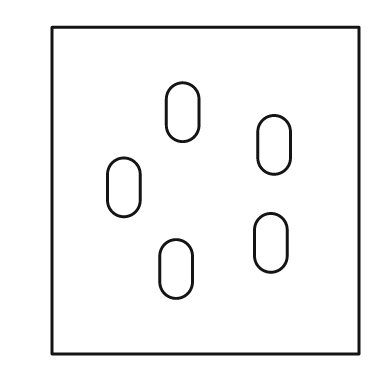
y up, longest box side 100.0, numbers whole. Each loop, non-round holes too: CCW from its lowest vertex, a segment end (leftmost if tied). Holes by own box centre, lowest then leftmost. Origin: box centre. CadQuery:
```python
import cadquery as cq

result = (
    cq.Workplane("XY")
    .moveTo(-47.0, -50.0)
    .lineTo(47.0, -50.0)
    .lineTo(47.0, 50.0)
    .lineTo(-47.0, 50.0)
    .close()
    .moveTo(-14.0, -28.0)
    .threePointArc((-9.0, -33.0), (-4.0, -28.0))
    .lineTo(-4.0, -20.0)
    .threePointArc((-9.0, -15.0), (-14.0, -20.0))
    .close()
    .moveTo(15.0, -20.0)
    .threePointArc((20.0, -25.0), (25.0, -20.0))
    .lineTo(25.0, -12.0)
    .threePointArc((20.0, -7.0), (15.0, -12.0))
    .close()
    .moveTo(-30.0, -3.0)
    .threePointArc((-25.0, -8.0), (-20.0, -3.0))
    .lineTo(-20.0, 5.0)
    .threePointArc((-25.0, 10.0), (-30.0, 5.0))
    .close()
    .moveTo(16.0, 10.0)
    .threePointArc((21.0, 5.0), (26.0, 10.0))
    .lineTo(26.0, 18.0)
    .threePointArc((21.0, 23.0), (16.0, 18.0))
    .close()
    .moveTo(-12.0, 20.0)
    .threePointArc((-7.0, 15.0), (-2.0, 20.0))
    .lineTo(-2.0, 28.0)
    .threePointArc((-7.0, 33.0), (-12.0, 28.0))
    .close()
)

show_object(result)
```